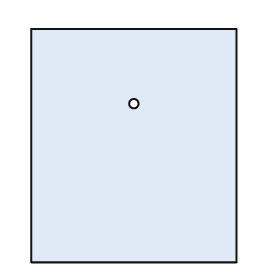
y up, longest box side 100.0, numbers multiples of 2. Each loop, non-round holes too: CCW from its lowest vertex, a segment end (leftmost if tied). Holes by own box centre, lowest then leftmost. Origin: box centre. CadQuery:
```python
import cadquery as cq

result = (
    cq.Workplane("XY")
    .moveTo(-44.0, -50.0)
    .lineTo(44.0, -50.0)
    .lineTo(44.0, 50.0)
    .lineTo(-44.0, 50.0)
    .close()
    .moveTo(0.0, 18.0)
    .circle(2.0)
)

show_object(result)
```